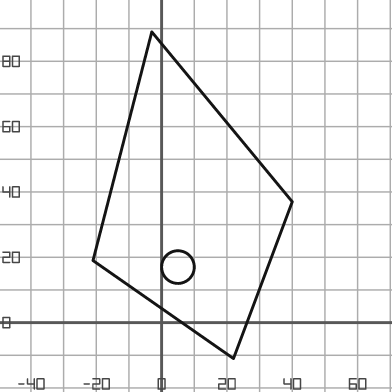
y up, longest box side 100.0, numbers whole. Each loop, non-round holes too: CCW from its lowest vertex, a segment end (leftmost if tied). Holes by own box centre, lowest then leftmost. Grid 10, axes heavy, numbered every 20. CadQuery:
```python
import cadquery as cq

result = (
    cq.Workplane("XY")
    .moveTo(22.0, -11.0)
    .lineTo(40.0, 37.0)
    .lineTo(-3.0, 89.0)
    .lineTo(-21.0, 19.0)
    .close()
    .moveTo(5.0, 17.0)
    .circle(5.0)
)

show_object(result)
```